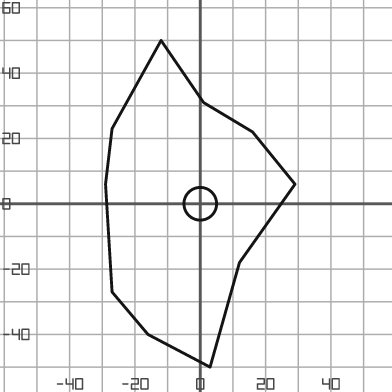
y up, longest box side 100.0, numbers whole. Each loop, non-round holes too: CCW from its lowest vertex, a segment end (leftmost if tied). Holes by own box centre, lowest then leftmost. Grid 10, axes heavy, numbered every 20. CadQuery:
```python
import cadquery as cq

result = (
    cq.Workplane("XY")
    .moveTo(3.0, -50.0)
    .lineTo(12.0, -18.0)
    .lineTo(29.0, 6.0)
    .lineTo(16.0, 22.0)
    .lineTo(1.0, 31.0)
    .lineTo(-12.0, 50.0)
    .lineTo(-27.0, 23.0)
    .lineTo(-29.0, 6.0)
    .lineTo(-27.0, -27.0)
    .lineTo(-16.0, -40.0)
    .close()
    .moveTo(0.0, 0.0)
    .circle(5.0)
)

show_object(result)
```